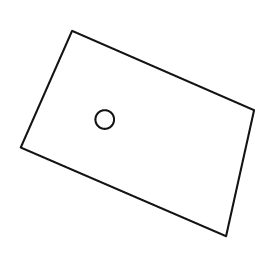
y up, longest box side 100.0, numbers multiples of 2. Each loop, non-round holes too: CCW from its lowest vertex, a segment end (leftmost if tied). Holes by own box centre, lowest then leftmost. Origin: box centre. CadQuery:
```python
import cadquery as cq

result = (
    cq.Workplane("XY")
    .moveTo(38.0, -44.0)
    .lineTo(50.0, 10.0)
    .lineTo(-28.0, 44.0)
    .lineTo(-50.0, -6.0)
    .close()
    .moveTo(-14.0, 6.0)
    .circle(4.0)
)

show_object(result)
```